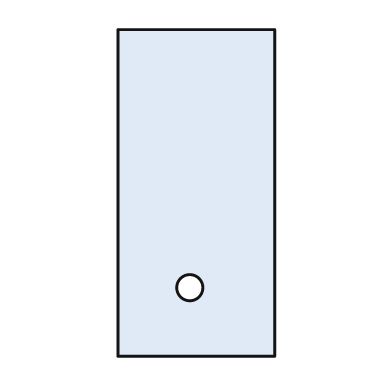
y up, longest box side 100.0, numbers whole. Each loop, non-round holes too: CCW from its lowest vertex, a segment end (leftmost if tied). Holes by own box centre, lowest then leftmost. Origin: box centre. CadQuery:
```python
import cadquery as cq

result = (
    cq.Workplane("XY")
    .moveTo(-24.0, -50.0)
    .lineTo(24.0, -50.0)
    .lineTo(24.0, 50.0)
    .lineTo(-24.0, 50.0)
    .close()
    .moveTo(-2.0, -29.0)
    .circle(4.0)
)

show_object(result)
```